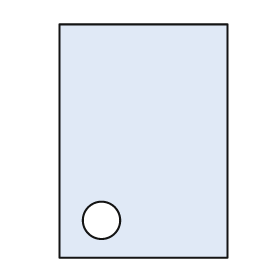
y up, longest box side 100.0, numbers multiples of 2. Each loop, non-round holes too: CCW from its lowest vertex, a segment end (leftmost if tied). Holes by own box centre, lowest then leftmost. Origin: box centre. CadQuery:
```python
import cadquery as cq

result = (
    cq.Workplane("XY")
    .moveTo(-36.0, -50.0)
    .lineTo(36.0, -50.0)
    .lineTo(36.0, 50.0)
    .lineTo(-36.0, 50.0)
    .close()
    .moveTo(-18.0, -34.0)
    .circle(8.0)
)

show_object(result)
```